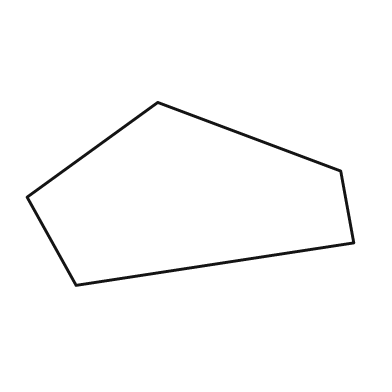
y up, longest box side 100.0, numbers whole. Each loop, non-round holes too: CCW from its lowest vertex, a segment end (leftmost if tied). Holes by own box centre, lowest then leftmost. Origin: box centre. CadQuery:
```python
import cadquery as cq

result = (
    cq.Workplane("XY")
    .moveTo(-35.0, -28.0)
    .lineTo(50.0, -15.0)
    .lineTo(46.0, 7.0)
    .lineTo(-10.0, 28.0)
    .lineTo(-50.0, -1.0)
    .close()
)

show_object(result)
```